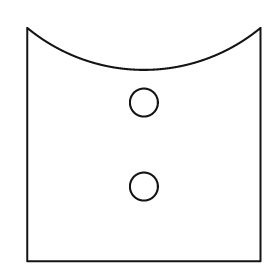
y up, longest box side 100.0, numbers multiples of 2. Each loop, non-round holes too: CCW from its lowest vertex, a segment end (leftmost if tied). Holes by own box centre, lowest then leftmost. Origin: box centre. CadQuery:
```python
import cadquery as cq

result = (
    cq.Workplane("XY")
    .moveTo(-50.0, -50.0)
    .lineTo(50.0, -50.0)
    .lineTo(50.0, 50.0)
    .threePointArc((0.0, 32.0), (-50.0, 50.0))
    .close()
    .moveTo(0.0, -18.0)
    .circle(6.0)
    .moveTo(0.0, 18.0)
    .circle(6.0)
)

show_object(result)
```